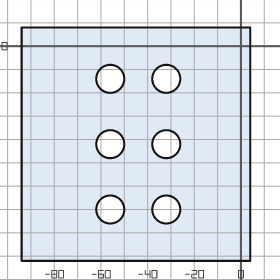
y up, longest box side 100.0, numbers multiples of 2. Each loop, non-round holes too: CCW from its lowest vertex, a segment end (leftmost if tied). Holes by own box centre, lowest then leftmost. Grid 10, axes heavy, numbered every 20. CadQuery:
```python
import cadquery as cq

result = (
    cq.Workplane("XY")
    .moveTo(-94.0, -92.0)
    .lineTo(4.0, -92.0)
    .lineTo(4.0, 8.0)
    .lineTo(-94.0, 8.0)
    .close()
    .moveTo(-56.0, -70.0)
    .circle(6.0)
    .moveTo(-32.0, -70.0)
    .circle(6.0)
    .moveTo(-56.0, -42.0)
    .circle(6.0)
    .moveTo(-32.0, -42.0)
    .circle(6.0)
    .moveTo(-56.0, -14.0)
    .circle(6.0)
    .moveTo(-32.0, -14.0)
    .circle(6.0)
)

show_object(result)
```